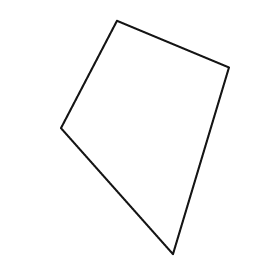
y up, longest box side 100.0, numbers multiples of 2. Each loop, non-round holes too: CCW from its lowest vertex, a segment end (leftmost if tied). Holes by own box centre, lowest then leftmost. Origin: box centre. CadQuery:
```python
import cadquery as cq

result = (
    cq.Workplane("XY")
    .moveTo(12.0, -50.0)
    .lineTo(36.0, 30.0)
    .lineTo(-12.0, 50.0)
    .lineTo(-36.0, 4.0)
    .close()
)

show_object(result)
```